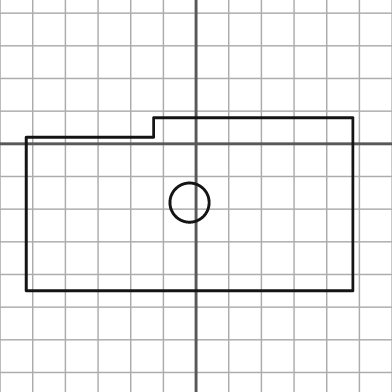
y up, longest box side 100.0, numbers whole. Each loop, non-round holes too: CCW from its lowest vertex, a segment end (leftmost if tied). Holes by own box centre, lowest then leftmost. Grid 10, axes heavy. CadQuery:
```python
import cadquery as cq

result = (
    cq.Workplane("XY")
    .moveTo(-52.0, -45.0)
    .lineTo(48.0, -45.0)
    .lineTo(48.0, 8.0)
    .lineTo(-13.0, 8.0)
    .lineTo(-13.0, 2.0)
    .lineTo(-52.0, 2.0)
    .close()
    .moveTo(-2.0, -18.0)
    .circle(6.0)
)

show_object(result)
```